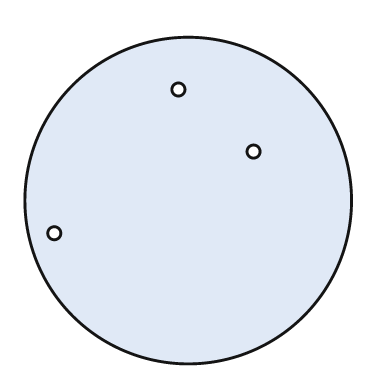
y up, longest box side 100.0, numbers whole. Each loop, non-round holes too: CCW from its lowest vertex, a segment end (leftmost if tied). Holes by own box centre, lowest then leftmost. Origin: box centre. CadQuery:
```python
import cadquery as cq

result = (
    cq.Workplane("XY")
    .moveTo(0.0, 0.0)
    .circle(50.0)
    .moveTo(-41.0, -10.0)
    .circle(2.0)
    .moveTo(20.0, 15.0)
    .circle(2.0)
    .moveTo(-3.0, 34.0)
    .circle(2.0)
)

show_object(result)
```